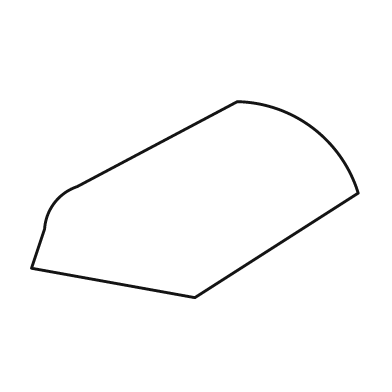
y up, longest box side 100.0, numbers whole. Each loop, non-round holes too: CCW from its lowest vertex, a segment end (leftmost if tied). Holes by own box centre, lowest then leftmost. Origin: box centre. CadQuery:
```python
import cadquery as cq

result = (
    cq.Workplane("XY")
    .moveTo(0.0, -30.0)
    .lineTo(50.0, 2.0)
    .threePointArc((36.0, 22.0), (13.0, 30.0))
    .lineTo(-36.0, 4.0)
    .threePointArc((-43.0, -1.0), (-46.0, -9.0))
    .lineTo(-50.0, -21.0)
    .close()
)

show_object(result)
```